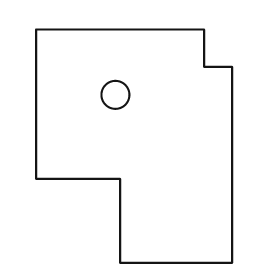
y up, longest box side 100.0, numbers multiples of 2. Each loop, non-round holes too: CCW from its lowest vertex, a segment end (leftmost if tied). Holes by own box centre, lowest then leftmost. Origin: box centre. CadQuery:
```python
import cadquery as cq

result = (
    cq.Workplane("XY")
    .moveTo(-6.0, -50.0)
    .lineTo(42.0, -50.0)
    .lineTo(42.0, 34.0)
    .lineTo(30.0, 34.0)
    .lineTo(30.0, 50.0)
    .lineTo(-42.0, 50.0)
    .lineTo(-42.0, -14.0)
    .lineTo(-6.0, -14.0)
    .close()
    .moveTo(-8.0, 22.0)
    .circle(6.0)
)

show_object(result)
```